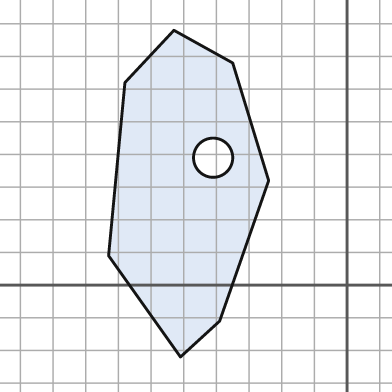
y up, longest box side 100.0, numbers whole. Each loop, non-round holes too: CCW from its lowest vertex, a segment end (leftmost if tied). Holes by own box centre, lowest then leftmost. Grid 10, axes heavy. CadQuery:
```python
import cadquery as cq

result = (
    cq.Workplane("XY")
    .moveTo(-51.0, -22.0)
    .lineTo(-39.0, -11.0)
    .lineTo(-24.0, 32.0)
    .lineTo(-35.0, 68.0)
    .lineTo(-53.0, 78.0)
    .lineTo(-68.0, 62.0)
    .lineTo(-73.0, 9.0)
    .close()
    .moveTo(-41.0, 39.0)
    .circle(6.0)
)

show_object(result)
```